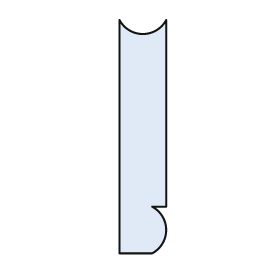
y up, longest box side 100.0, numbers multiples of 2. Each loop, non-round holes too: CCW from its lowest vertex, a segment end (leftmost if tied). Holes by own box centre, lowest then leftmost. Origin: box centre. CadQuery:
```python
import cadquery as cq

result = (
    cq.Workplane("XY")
    .moveTo(-10.0, -50.0)
    .lineTo(4.0, -50.0)
    .threePointArc((10.0, -40.0), (4.0, -30.0))
    .lineTo(10.0, -30.0)
    .lineTo(10.0, 50.0)
    .threePointArc((0.0, 44.0), (-10.0, 50.0))
    .close()
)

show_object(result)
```